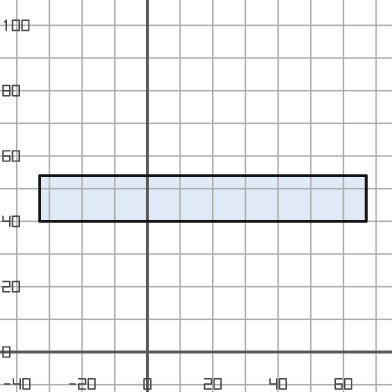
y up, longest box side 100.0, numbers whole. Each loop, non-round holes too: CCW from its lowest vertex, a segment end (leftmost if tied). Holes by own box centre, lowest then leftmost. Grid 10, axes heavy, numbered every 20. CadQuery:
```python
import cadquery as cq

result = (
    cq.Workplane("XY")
    .moveTo(-33.0, 40.0)
    .lineTo(67.0, 40.0)
    .lineTo(67.0, 54.0)
    .lineTo(-33.0, 54.0)
    .close()
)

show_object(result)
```